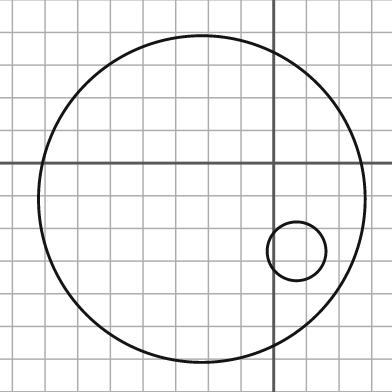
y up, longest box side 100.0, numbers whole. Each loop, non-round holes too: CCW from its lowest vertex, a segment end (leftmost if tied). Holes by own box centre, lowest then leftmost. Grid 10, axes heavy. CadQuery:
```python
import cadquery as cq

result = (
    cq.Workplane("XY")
    .moveTo(-22.0, -11.0)
    .circle(50.0)
    .moveTo(7.0, -27.0)
    .circle(9.0)
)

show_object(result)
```